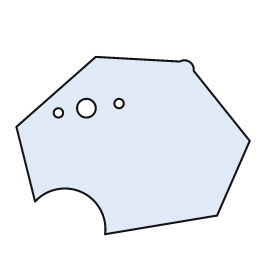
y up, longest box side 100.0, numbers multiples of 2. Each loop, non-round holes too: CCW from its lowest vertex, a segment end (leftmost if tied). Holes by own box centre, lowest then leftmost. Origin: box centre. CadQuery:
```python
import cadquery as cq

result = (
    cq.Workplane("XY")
    .moveTo(-12.0, -38.0)
    .lineTo(36.0, -30.0)
    .lineTo(50.0, 2.0)
    .lineTo(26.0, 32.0)
    .threePointArc((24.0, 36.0), (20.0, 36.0))
    .lineTo(-16.0, 38.0)
    .lineTo(-50.0, 8.0)
    .lineTo(-42.0, -24.0)
    .threePointArc((-22.0, -20.0), (-12.0, -38.0))
    .close()
    .moveTo(-32.0, 14.0)
    .circle(2.0)
    .moveTo(-20.0, 16.0)
    .circle(4.0)
    .moveTo(-6.0, 18.0)
    .circle(2.0)
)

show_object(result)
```